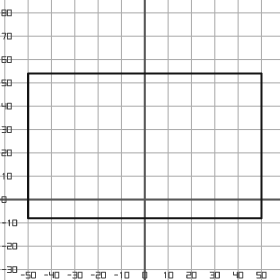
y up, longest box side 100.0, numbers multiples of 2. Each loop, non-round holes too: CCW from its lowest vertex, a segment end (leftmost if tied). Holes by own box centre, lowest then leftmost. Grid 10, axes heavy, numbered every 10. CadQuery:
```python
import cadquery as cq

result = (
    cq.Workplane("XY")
    .moveTo(-50.0, -8.0)
    .lineTo(50.0, -8.0)
    .lineTo(50.0, 54.0)
    .lineTo(-50.0, 54.0)
    .close()
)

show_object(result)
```